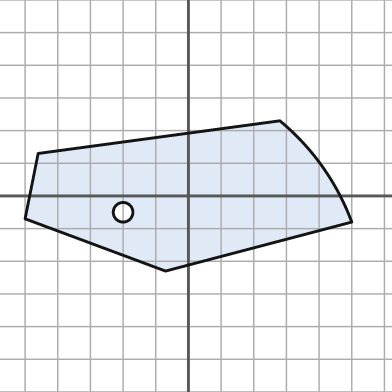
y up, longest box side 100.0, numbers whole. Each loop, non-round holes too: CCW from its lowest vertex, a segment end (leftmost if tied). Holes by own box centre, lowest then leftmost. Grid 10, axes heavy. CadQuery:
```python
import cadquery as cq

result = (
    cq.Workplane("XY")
    .moveTo(-7.0, -23.0)
    .lineTo(50.0, -8.0)
    .threePointArc((41.0, 9.0), (28.0, 23.0))
    .lineTo(-46.0, 13.0)
    .lineTo(-50.0, -7.0)
    .close()
    .moveTo(-20.0, -5.0)
    .circle(3.0)
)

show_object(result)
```